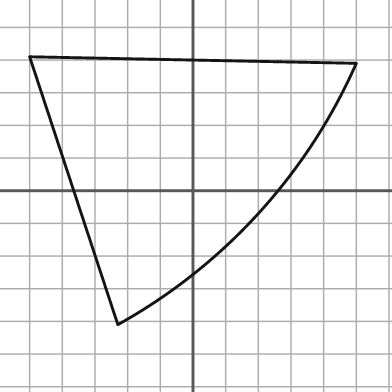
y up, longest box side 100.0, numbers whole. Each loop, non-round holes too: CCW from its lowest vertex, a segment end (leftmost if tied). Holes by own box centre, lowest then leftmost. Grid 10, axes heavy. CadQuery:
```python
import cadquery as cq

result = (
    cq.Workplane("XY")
    .moveTo(-23.0, -41.0)
    .threePointArc((20.0, -7.0), (50.0, 39.0))
    .lineTo(-50.0, 41.0)
    .close()
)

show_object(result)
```